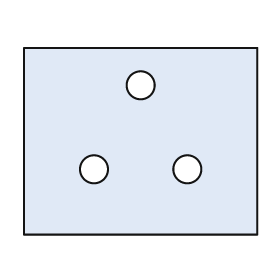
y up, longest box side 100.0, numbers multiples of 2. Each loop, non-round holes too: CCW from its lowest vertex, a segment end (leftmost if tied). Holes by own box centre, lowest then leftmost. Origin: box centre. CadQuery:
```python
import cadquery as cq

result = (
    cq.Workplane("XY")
    .moveTo(-50.0, -40.0)
    .lineTo(50.0, -40.0)
    .lineTo(50.0, 40.0)
    .lineTo(-50.0, 40.0)
    .close()
    .moveTo(-20.0, -12.0)
    .circle(6.0)
    .moveTo(20.0, -12.0)
    .circle(6.0)
    .moveTo(0.0, 24.0)
    .circle(6.0)
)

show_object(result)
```